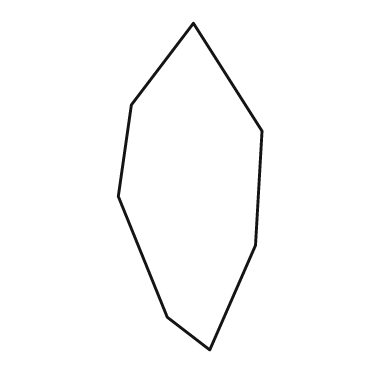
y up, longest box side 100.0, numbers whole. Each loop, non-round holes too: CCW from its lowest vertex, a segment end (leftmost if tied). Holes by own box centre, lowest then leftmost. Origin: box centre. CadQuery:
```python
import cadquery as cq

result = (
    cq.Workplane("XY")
    .moveTo(6.0, -50.0)
    .lineTo(20.0, -18.0)
    .lineTo(22.0, 17.0)
    .lineTo(1.0, 50.0)
    .lineTo(-18.0, 25.0)
    .lineTo(-22.0, -3.0)
    .lineTo(-7.0, -40.0)
    .close()
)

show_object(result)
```